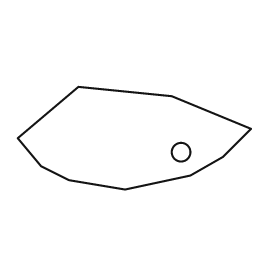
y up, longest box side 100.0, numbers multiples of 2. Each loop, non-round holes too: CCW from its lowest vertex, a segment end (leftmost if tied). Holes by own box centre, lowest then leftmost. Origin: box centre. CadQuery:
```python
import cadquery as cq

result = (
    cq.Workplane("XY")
    .moveTo(-4.0, -22.0)
    .lineTo(24.0, -16.0)
    .lineTo(38.0, -8.0)
    .lineTo(50.0, 4.0)
    .lineTo(16.0, 18.0)
    .lineTo(-24.0, 22.0)
    .lineTo(-50.0, 0.0)
    .lineTo(-40.0, -12.0)
    .lineTo(-28.0, -18.0)
    .close()
    .moveTo(20.0, -6.0)
    .circle(4.0)
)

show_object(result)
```